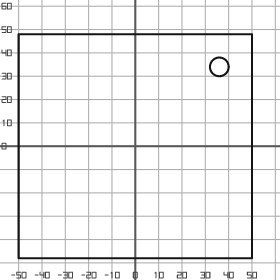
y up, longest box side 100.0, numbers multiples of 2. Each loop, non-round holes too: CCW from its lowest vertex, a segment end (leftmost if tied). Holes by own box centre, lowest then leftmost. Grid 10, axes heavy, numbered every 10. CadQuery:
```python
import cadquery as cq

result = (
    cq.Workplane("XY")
    .moveTo(-50.0, -48.0)
    .lineTo(50.0, -48.0)
    .lineTo(50.0, 48.0)
    .lineTo(-50.0, 48.0)
    .close()
    .moveTo(36.0, 34.0)
    .circle(4.0)
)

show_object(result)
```